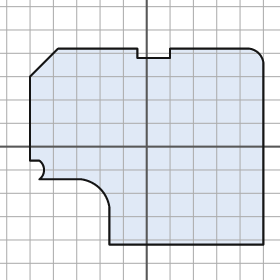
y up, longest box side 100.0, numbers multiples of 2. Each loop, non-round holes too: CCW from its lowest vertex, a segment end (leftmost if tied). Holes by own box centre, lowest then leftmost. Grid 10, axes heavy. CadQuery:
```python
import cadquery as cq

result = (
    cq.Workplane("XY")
    .moveTo(-16.0, -42.0)
    .lineTo(50.0, -42.0)
    .lineTo(50.0, 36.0)
    .threePointArc((48.0, 40.0), (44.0, 42.0))
    .lineTo(10.0, 42.0)
    .lineTo(10.0, 38.0)
    .lineTo(-4.0, 38.0)
    .lineTo(-4.0, 42.0)
    .lineTo(-38.0, 42.0)
    .lineTo(-50.0, 30.0)
    .lineTo(-50.0, -6.0)
    .lineTo(-46.0, -6.0)
    .threePointArc((-44.0, -10.0), (-46.0, -14.0))
    .lineTo(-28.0, -14.0)
    .threePointArc((-20.0, -18.0), (-16.0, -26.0))
    .close()
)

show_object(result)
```